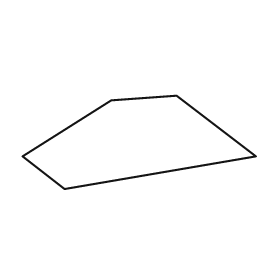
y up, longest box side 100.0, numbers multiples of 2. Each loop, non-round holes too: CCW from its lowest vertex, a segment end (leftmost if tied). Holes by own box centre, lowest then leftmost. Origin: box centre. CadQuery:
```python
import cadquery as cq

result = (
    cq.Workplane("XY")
    .moveTo(-32.0, -20.0)
    .lineTo(50.0, -6.0)
    .lineTo(16.0, 20.0)
    .lineTo(-12.0, 18.0)
    .lineTo(-50.0, -6.0)
    .close()
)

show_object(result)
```